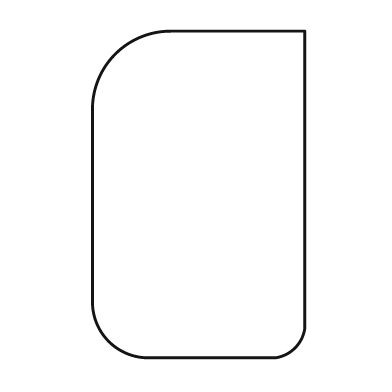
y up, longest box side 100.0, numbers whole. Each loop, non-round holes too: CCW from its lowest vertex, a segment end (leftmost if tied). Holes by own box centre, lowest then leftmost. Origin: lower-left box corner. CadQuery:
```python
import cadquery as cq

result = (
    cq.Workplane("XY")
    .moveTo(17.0, 0.0)
    .lineTo(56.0, 0.0)
    .threePointArc((62.0, 3.0), (65.0, 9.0))
    .lineTo(65.0, 100.0)
    .lineTo(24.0, 100.0)
    .threePointArc((7.0, 93.0), (0.0, 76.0))
    .lineTo(0.0, 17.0)
    .threePointArc((5.0, 5.0), (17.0, 0.0))
    .close()
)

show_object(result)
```